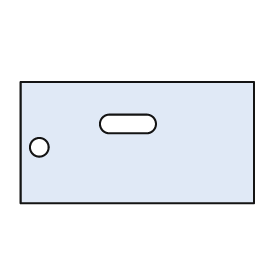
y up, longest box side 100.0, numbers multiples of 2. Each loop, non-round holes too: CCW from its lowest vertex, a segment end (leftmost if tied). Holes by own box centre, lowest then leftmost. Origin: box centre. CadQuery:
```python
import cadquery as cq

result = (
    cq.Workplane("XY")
    .moveTo(-50.0, -26.0)
    .lineTo(50.0, -26.0)
    .lineTo(50.0, 26.0)
    .lineTo(-50.0, 26.0)
    .close()
    .moveTo(-42.0, -2.0)
    .circle(4.0)
    .moveTo(-12.0, 4.0)
    .lineTo(4.0, 4.0)
    .threePointArc((8.0, 8.0), (4.0, 12.0))
    .lineTo(-12.0, 12.0)
    .threePointArc((-16.0, 8.0), (-12.0, 4.0))
    .close()
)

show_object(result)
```